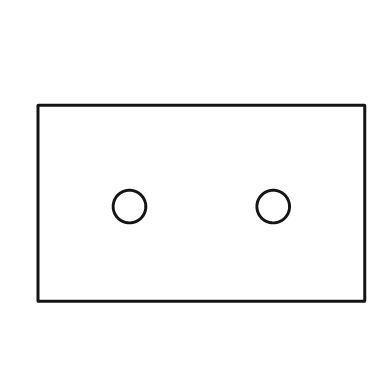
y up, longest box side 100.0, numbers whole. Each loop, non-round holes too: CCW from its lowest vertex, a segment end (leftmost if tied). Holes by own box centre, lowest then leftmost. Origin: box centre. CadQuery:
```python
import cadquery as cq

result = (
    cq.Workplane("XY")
    .moveTo(-50.0, -30.0)
    .lineTo(50.0, -30.0)
    .lineTo(50.0, 30.0)
    .lineTo(-50.0, 30.0)
    .close()
    .moveTo(-22.0, -1.0)
    .circle(5.0)
    .moveTo(22.0, -1.0)
    .circle(5.0)
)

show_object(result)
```